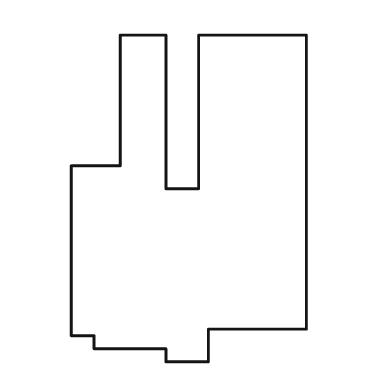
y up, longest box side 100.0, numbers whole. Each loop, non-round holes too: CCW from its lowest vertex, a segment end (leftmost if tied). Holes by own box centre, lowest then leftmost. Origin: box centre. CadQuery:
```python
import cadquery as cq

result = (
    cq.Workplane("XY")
    .moveTo(-7.0, -50.0)
    .lineTo(6.0, -50.0)
    .lineTo(6.0, -40.0)
    .lineTo(36.0, -40.0)
    .lineTo(36.0, 50.0)
    .lineTo(3.0, 50.0)
    .lineTo(3.0, 3.0)
    .lineTo(-7.0, 3.0)
    .lineTo(-7.0, 50.0)
    .lineTo(-21.0, 50.0)
    .lineTo(-21.0, 10.0)
    .lineTo(-36.0, 10.0)
    .lineTo(-36.0, -42.0)
    .lineTo(-29.0, -42.0)
    .lineTo(-29.0, -46.0)
    .lineTo(-7.0, -46.0)
    .close()
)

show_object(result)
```